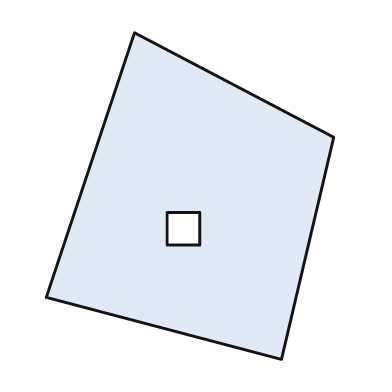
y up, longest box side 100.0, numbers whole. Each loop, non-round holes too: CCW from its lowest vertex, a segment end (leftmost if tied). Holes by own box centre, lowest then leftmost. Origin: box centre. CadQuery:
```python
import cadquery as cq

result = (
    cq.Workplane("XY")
    .moveTo(28.0, -50.0)
    .lineTo(44.0, 18.0)
    .lineTo(-17.0, 50.0)
    .lineTo(-44.0, -31.0)
    .close()
    .moveTo(-7.0, -15.0)
    .lineTo(3.0, -15.0)
    .lineTo(3.0, -5.0)
    .lineTo(-7.0, -5.0)
    .close()
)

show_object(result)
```